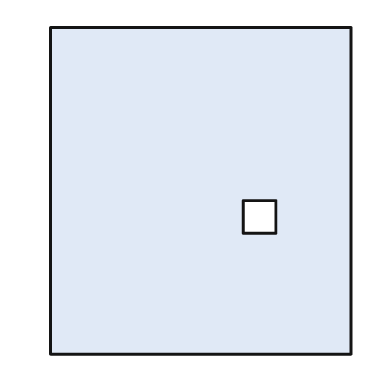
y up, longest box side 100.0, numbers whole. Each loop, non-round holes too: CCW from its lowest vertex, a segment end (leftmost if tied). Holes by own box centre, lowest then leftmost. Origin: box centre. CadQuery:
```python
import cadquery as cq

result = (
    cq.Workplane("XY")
    .moveTo(-46.0, -50.0)
    .lineTo(46.0, -50.0)
    .lineTo(46.0, 50.0)
    .lineTo(-46.0, 50.0)
    .close()
    .moveTo(13.0, -13.0)
    .lineTo(23.0, -13.0)
    .lineTo(23.0, -3.0)
    .lineTo(13.0, -3.0)
    .close()
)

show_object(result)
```